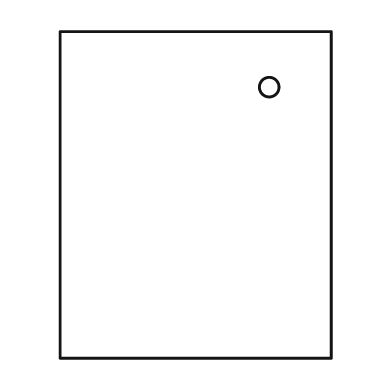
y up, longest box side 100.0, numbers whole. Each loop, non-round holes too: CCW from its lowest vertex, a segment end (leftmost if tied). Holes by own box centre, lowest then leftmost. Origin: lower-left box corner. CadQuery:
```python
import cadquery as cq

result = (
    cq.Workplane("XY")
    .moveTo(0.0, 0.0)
    .lineTo(83.0, 0.0)
    .lineTo(83.0, 100.0)
    .lineTo(0.0, 100.0)
    .close()
    .moveTo(64.0, 83.0)
    .circle(3.0)
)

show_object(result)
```